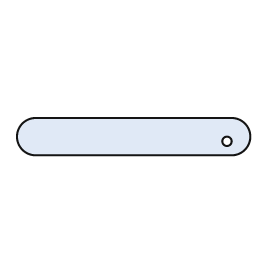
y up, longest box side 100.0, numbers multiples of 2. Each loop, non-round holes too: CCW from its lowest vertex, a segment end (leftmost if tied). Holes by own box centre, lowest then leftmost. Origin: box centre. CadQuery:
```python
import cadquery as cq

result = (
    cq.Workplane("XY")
    .moveTo(-42.0, -8.0)
    .lineTo(42.0, -8.0)
    .threePointArc((50.0, 0.0), (42.0, 8.0))
    .lineTo(-42.0, 8.0)
    .threePointArc((-50.0, 0.0), (-42.0, -8.0))
    .close()
    .moveTo(40.0, -2.0)
    .circle(2.0)
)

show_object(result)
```